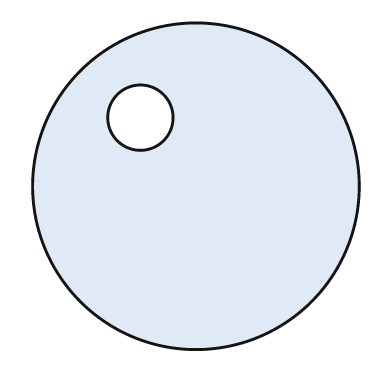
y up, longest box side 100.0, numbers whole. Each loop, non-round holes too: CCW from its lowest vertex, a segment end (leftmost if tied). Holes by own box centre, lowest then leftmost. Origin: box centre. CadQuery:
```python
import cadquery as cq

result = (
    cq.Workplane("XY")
    .moveTo(0.0, 0.0)
    .circle(50.0)
    .moveTo(-17.0, 21.0)
    .circle(10.0)
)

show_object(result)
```